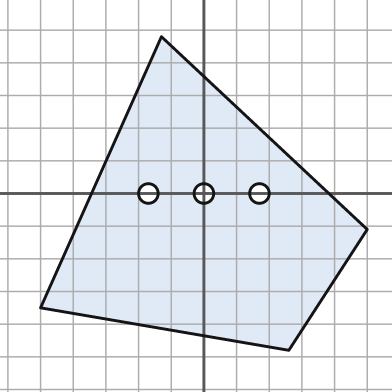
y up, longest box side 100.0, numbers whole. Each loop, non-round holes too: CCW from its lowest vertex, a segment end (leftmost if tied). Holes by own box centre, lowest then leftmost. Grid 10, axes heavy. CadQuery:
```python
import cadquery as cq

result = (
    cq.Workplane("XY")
    .moveTo(26.0, -48.0)
    .lineTo(50.0, -11.0)
    .lineTo(-13.0, 48.0)
    .lineTo(-50.0, -35.0)
    .close()
    .moveTo(-17.0, 0.0)
    .circle(3.0)
    .moveTo(0.0, 0.0)
    .circle(3.0)
    .moveTo(17.0, 0.0)
    .circle(3.0)
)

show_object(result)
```